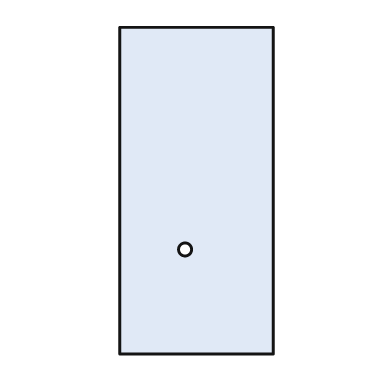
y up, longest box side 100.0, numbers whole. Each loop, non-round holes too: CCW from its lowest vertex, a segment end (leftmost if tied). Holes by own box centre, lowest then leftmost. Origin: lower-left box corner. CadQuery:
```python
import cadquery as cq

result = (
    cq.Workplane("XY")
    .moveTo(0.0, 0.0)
    .lineTo(47.0, 0.0)
    .lineTo(47.0, 100.0)
    .lineTo(0.0, 100.0)
    .close()
    .moveTo(20.0, 32.0)
    .circle(2.0)
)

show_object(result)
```